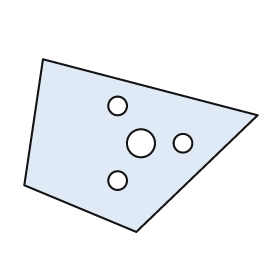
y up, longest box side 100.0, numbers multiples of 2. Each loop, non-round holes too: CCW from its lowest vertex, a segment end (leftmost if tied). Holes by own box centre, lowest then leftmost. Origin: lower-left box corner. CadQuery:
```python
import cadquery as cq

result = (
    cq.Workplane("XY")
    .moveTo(48.0, 0.0)
    .lineTo(100.0, 50.0)
    .lineTo(8.0, 74.0)
    .lineTo(0.0, 20.0)
    .close()
    .moveTo(40.0, 22.0)
    .circle(4.0)
    .moveTo(50.0, 38.0)
    .circle(6.0)
    .moveTo(68.0, 38.0)
    .circle(4.0)
    .moveTo(40.0, 54.0)
    .circle(4.0)
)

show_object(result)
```